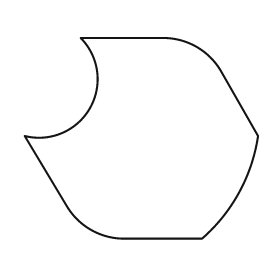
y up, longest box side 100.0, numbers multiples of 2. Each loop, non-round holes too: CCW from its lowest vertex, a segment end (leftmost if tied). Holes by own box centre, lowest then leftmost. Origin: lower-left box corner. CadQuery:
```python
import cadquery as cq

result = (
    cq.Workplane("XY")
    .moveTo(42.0, 0.0)
    .lineTo(76.0, 0.0)
    .threePointArc((92.0, 20.0), (100.0, 44.0))
    .lineTo(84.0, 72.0)
    .threePointArc((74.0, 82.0), (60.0, 86.0))
    .lineTo(24.0, 86.0)
    .threePointArc((28.0, 56.0), (0.0, 44.0))
    .lineTo(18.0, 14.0)
    .threePointArc((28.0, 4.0), (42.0, 0.0))
    .close()
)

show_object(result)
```